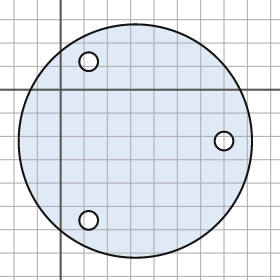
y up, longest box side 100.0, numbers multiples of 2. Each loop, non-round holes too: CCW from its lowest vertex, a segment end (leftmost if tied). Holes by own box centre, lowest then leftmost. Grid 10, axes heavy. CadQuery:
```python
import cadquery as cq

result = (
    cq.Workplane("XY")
    .moveTo(32.0, -22.0)
    .circle(50.0)
    .moveTo(12.0, -56.0)
    .circle(4.0)
    .moveTo(70.0, -22.0)
    .circle(4.0)
    .moveTo(12.0, 12.0)
    .circle(4.0)
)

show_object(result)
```